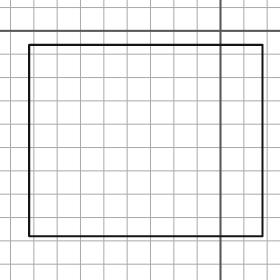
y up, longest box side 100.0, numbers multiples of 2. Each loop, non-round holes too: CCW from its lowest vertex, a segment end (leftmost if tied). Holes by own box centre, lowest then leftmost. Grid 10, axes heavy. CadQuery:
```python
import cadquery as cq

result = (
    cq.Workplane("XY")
    .moveTo(-82.0, -88.0)
    .lineTo(18.0, -88.0)
    .lineTo(18.0, -6.0)
    .lineTo(-82.0, -6.0)
    .close()
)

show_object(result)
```